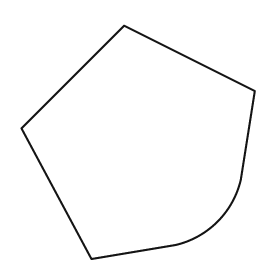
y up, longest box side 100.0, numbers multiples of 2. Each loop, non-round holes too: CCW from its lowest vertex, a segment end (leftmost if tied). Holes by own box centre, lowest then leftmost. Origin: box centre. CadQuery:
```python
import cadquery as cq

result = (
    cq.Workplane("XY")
    .moveTo(-20.0, -50.0)
    .lineTo(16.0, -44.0)
    .threePointArc((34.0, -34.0), (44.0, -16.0))
    .lineTo(50.0, 22.0)
    .lineTo(-6.0, 50.0)
    .lineTo(-50.0, 6.0)
    .close()
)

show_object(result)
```